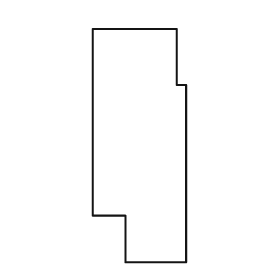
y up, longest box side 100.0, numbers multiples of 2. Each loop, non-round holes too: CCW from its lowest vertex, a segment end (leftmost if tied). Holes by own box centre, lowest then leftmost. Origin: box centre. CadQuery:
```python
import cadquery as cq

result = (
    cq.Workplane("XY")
    .moveTo(-6.0, -50.0)
    .lineTo(20.0, -50.0)
    .lineTo(20.0, 26.0)
    .lineTo(16.0, 26.0)
    .lineTo(16.0, 50.0)
    .lineTo(-20.0, 50.0)
    .lineTo(-20.0, -30.0)
    .lineTo(-6.0, -30.0)
    .close()
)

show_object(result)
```